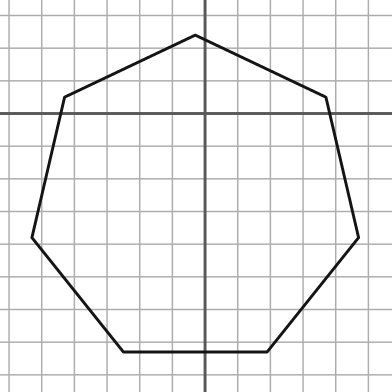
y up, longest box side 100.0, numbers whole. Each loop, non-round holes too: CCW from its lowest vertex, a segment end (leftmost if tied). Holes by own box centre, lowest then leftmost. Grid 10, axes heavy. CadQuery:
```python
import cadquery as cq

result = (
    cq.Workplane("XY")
    .moveTo(-25.0, -73.0)
    .lineTo(19.0, -73.0)
    .lineTo(47.0, -38.0)
    .lineTo(37.0, 5.0)
    .lineTo(-3.0, 24.0)
    .lineTo(-43.0, 5.0)
    .lineTo(-53.0, -38.0)
    .close()
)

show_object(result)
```